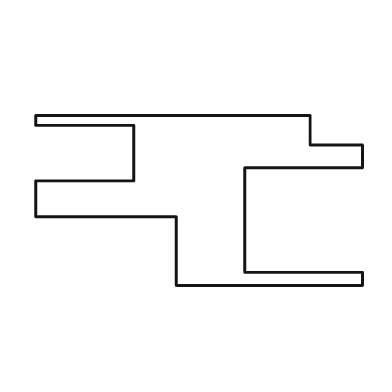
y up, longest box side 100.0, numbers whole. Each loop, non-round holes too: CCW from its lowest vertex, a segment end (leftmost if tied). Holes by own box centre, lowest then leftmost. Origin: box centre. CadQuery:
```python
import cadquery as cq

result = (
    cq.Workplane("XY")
    .moveTo(-7.0, -26.0)
    .lineTo(50.0, -26.0)
    .lineTo(50.0, -22.0)
    .lineTo(14.0, -22.0)
    .lineTo(14.0, 10.0)
    .lineTo(50.0, 10.0)
    .lineTo(50.0, 17.0)
    .lineTo(34.0, 17.0)
    .lineTo(34.0, 26.0)
    .lineTo(-50.0, 26.0)
    .lineTo(-50.0, 23.0)
    .lineTo(-20.0, 23.0)
    .lineTo(-20.0, 6.0)
    .lineTo(-50.0, 6.0)
    .lineTo(-50.0, -5.0)
    .lineTo(-7.0, -5.0)
    .close()
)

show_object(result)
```